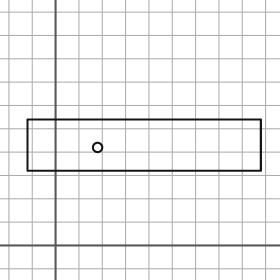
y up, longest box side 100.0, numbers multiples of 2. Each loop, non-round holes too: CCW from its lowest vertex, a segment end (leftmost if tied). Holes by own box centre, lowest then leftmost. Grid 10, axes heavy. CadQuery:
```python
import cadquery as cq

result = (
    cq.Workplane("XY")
    .moveTo(-12.0, 32.0)
    .lineTo(88.0, 32.0)
    .lineTo(88.0, 54.0)
    .lineTo(-12.0, 54.0)
    .close()
    .moveTo(18.0, 42.0)
    .circle(2.0)
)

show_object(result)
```